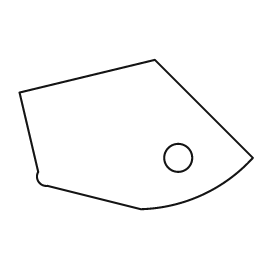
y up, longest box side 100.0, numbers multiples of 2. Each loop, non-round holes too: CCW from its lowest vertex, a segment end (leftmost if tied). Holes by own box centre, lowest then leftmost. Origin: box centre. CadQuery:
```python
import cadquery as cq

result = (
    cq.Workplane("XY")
    .moveTo(2.0, -32.0)
    .threePointArc((28.0, -26.0), (50.0, -10.0))
    .lineTo(8.0, 32.0)
    .lineTo(-50.0, 18.0)
    .lineTo(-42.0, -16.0)
    .threePointArc((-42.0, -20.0), (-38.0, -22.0))
    .close()
    .moveTo(18.0, -10.0)
    .circle(6.0)
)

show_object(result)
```